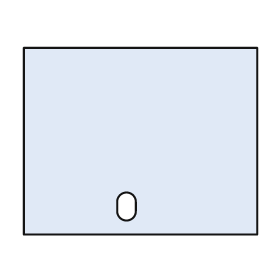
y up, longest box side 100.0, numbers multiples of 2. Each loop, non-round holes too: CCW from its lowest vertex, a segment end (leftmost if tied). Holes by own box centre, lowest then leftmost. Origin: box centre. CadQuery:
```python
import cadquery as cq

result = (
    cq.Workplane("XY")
    .moveTo(-50.0, -40.0)
    .lineTo(50.0, -40.0)
    .lineTo(50.0, 40.0)
    .lineTo(-50.0, 40.0)
    .close()
    .moveTo(-10.0, -30.0)
    .threePointArc((-6.0, -34.0), (-2.0, -30.0))
    .lineTo(-2.0, -26.0)
    .threePointArc((-6.0, -22.0), (-10.0, -26.0))
    .close()
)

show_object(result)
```